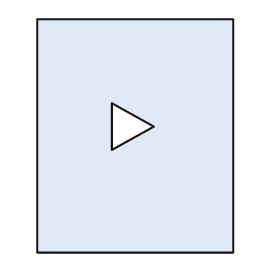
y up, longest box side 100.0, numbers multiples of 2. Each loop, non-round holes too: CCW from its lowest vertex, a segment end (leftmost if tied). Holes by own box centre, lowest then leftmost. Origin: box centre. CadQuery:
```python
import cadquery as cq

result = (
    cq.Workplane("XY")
    .moveTo(-42.0, -50.0)
    .lineTo(42.0, -50.0)
    .lineTo(42.0, 50.0)
    .lineTo(-42.0, 50.0)
    .close()
    .moveTo(-10.0, -6.0)
    .lineTo(8.0, 4.0)
    .lineTo(-10.0, 14.0)
    .close()
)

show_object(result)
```